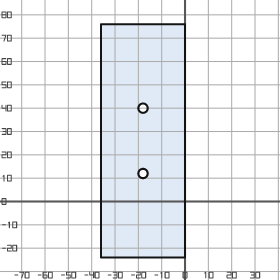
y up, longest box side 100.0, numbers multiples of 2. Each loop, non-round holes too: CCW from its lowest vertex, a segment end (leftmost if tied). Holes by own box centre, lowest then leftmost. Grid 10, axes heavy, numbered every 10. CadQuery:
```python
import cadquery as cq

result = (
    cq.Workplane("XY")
    .moveTo(-36.0, -24.0)
    .lineTo(0.0, -24.0)
    .lineTo(0.0, 76.0)
    .lineTo(-36.0, 76.0)
    .close()
    .moveTo(-18.0, 12.0)
    .circle(2.0)
    .moveTo(-18.0, 40.0)
    .circle(2.0)
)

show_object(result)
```